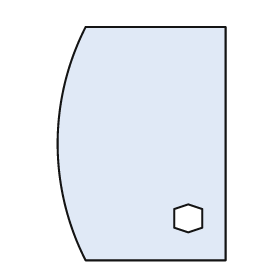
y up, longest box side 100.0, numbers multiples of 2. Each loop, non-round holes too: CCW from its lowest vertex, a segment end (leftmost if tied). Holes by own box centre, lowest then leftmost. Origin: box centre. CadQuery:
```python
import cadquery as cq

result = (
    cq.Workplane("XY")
    .moveTo(-24.0, -50.0)
    .lineTo(36.0, -50.0)
    .lineTo(36.0, 50.0)
    .lineTo(-24.0, 50.0)
    .threePointArc((-36.0, 0.0), (-24.0, -50.0))
    .close()
    .moveTo(20.0, -38.0)
    .lineTo(26.0, -36.0)
    .lineTo(26.0, -28.0)
    .lineTo(20.0, -26.0)
    .lineTo(14.0, -28.0)
    .lineTo(14.0, -36.0)
    .close()
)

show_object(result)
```